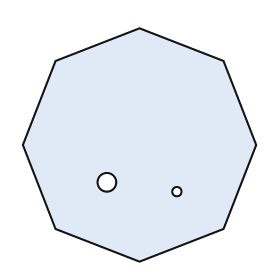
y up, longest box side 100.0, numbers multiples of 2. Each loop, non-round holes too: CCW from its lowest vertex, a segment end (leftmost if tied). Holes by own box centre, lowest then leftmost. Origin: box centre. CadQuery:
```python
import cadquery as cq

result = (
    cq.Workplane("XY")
    .moveTo(0.0, -50.0)
    .lineTo(36.0, -36.0)
    .lineTo(50.0, 0.0)
    .lineTo(36.0, 36.0)
    .lineTo(0.0, 50.0)
    .lineTo(-36.0, 36.0)
    .lineTo(-50.0, 0.0)
    .lineTo(-36.0, -36.0)
    .close()
    .moveTo(16.0, -20.0)
    .circle(2.0)
    .moveTo(-14.0, -16.0)
    .circle(4.0)
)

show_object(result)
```